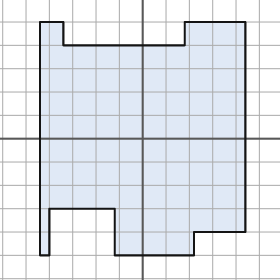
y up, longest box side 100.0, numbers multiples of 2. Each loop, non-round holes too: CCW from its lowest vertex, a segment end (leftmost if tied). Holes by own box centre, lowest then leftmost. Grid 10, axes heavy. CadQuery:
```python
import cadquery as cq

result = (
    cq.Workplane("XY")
    .moveTo(-44.0, -50.0)
    .lineTo(-40.0, -50.0)
    .lineTo(-40.0, -30.0)
    .lineTo(-12.0, -30.0)
    .lineTo(-12.0, -50.0)
    .lineTo(22.0, -50.0)
    .lineTo(22.0, -40.0)
    .lineTo(44.0, -40.0)
    .lineTo(44.0, 50.0)
    .lineTo(18.0, 50.0)
    .lineTo(18.0, 40.0)
    .lineTo(-34.0, 40.0)
    .lineTo(-34.0, 50.0)
    .lineTo(-44.0, 50.0)
    .close()
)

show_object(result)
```